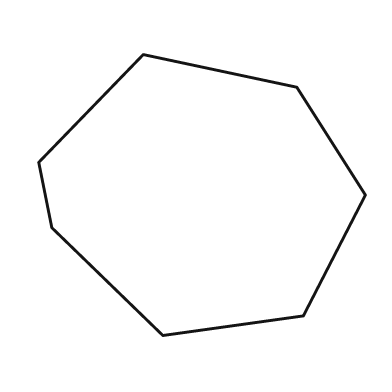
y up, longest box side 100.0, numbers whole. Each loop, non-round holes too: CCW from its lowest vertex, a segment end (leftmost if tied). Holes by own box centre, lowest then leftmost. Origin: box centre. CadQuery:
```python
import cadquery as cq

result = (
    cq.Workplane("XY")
    .moveTo(-12.0, -43.0)
    .lineTo(31.0, -37.0)
    .lineTo(50.0, 0.0)
    .lineTo(29.0, 33.0)
    .lineTo(-18.0, 43.0)
    .lineTo(-50.0, 10.0)
    .lineTo(-46.0, -10.0)
    .close()
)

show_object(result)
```